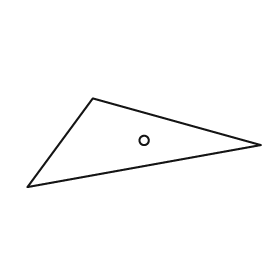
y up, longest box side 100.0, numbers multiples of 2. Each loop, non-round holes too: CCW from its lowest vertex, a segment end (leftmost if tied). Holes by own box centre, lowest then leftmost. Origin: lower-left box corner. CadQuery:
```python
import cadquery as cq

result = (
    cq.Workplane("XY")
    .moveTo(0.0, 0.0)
    .lineTo(100.0, 18.0)
    .lineTo(28.0, 38.0)
    .close()
    .moveTo(50.0, 20.0)
    .circle(2.0)
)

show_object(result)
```